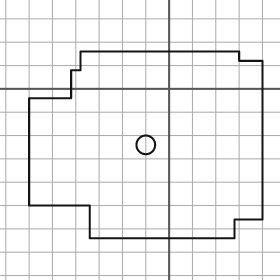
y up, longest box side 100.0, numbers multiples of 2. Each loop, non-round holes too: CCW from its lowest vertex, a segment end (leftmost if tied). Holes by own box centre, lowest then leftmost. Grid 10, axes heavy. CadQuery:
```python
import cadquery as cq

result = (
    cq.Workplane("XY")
    .moveTo(-34.0, -64.0)
    .lineTo(28.0, -64.0)
    .lineTo(28.0, -56.0)
    .lineTo(40.0, -56.0)
    .lineTo(40.0, 12.0)
    .lineTo(30.0, 12.0)
    .lineTo(30.0, 16.0)
    .lineTo(-38.0, 16.0)
    .lineTo(-38.0, 8.0)
    .lineTo(-42.0, 8.0)
    .lineTo(-42.0, -4.0)
    .lineTo(-60.0, -4.0)
    .lineTo(-60.0, -50.0)
    .lineTo(-34.0, -50.0)
    .close()
    .moveTo(-10.0, -24.0)
    .circle(4.0)
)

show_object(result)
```